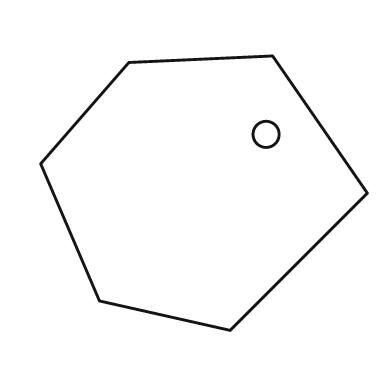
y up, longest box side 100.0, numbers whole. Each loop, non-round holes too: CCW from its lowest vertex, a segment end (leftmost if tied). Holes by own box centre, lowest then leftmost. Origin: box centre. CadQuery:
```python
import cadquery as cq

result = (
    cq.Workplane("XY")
    .moveTo(8.0, -42.0)
    .lineTo(50.0, 0.0)
    .lineTo(21.0, 42.0)
    .lineTo(-23.0, 40.0)
    .lineTo(-50.0, 9.0)
    .lineTo(-32.0, -33.0)
    .close()
    .moveTo(19.0, 18.0)
    .circle(4.0)
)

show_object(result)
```